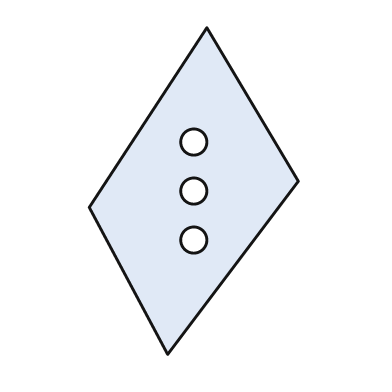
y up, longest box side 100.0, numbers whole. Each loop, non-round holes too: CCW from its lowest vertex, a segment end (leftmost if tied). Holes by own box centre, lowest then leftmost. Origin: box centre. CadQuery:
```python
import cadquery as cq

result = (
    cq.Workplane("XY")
    .moveTo(-8.0, -50.0)
    .lineTo(32.0, 3.0)
    .lineTo(4.0, 50.0)
    .lineTo(-32.0, -5.0)
    .close()
    .moveTo(0.0, -15.0)
    .circle(4.0)
    .moveTo(0.0, 0.0)
    .circle(4.0)
    .moveTo(0.0, 15.0)
    .circle(4.0)
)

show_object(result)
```